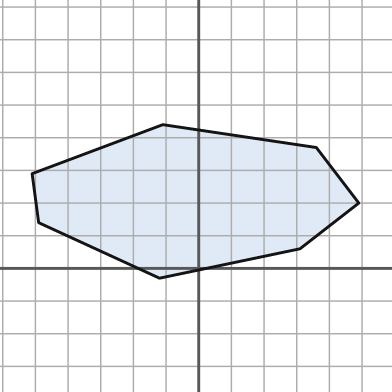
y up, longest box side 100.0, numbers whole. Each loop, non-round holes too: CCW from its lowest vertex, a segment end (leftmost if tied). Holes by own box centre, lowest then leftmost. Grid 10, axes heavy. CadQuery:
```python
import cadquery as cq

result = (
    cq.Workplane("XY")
    .moveTo(-12.0, -3.0)
    .lineTo(31.0, 6.0)
    .lineTo(49.0, 20.0)
    .lineTo(36.0, 37.0)
    .lineTo(-11.0, 44.0)
    .lineTo(-51.0, 29.0)
    .lineTo(-49.0, 14.0)
    .close()
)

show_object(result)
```